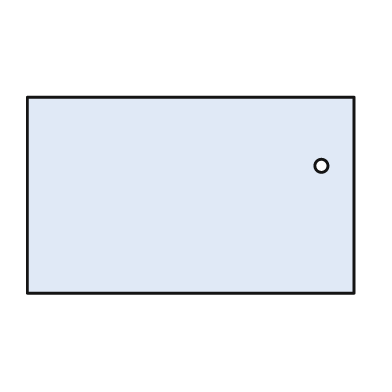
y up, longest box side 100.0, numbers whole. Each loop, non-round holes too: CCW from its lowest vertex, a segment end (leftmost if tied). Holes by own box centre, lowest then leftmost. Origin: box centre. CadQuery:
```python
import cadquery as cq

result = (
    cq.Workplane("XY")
    .moveTo(-50.0, -30.0)
    .lineTo(50.0, -30.0)
    .lineTo(50.0, 30.0)
    .lineTo(-50.0, 30.0)
    .close()
    .moveTo(40.0, 9.0)
    .circle(2.0)
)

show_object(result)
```